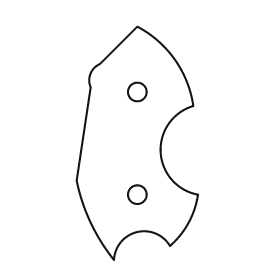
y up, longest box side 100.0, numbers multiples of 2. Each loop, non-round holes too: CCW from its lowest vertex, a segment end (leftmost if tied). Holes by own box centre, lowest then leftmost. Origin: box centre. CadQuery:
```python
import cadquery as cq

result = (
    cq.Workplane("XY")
    .moveTo(-10.0, -50.0)
    .threePointArc((0.0, -38.0), (14.0, -44.0))
    .threePointArc((22.0, -34.0), (26.0, -22.0))
    .threePointArc((10.0, -4.0), (24.0, 16.0))
    .threePointArc((16.0, 36.0), (0.0, 50.0))
    .lineTo(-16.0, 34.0)
    .threePointArc((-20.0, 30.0), (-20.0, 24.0))
    .lineTo(-26.0, -16.0)
    .threePointArc((-20.0, -34.0), (-10.0, -50.0))
    .close()
    .moveTo(0.0, -22.0)
    .circle(4.0)
    .moveTo(0.0, 22.0)
    .circle(4.0)
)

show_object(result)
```